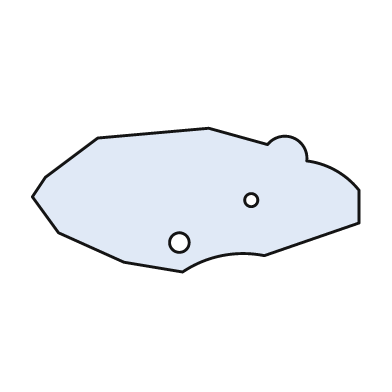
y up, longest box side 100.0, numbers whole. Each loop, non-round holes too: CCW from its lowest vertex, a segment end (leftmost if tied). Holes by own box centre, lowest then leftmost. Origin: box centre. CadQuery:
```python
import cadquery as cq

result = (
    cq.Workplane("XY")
    .moveTo(-4.0, -22.0)
    .threePointArc((8.0, -17.0), (21.0, -17.0))
    .lineTo(50.0, -7.0)
    .lineTo(50.0, 3.0)
    .threePointArc((43.0, 9.0), (34.0, 12.0))
    .threePointArc((30.0, 19.0), (22.0, 17.0))
    .lineTo(4.0, 22.0)
    .lineTo(-30.0, 19.0)
    .lineTo(-46.0, 7.0)
    .lineTo(-50.0, 1.0)
    .lineTo(-42.0, -10.0)
    .lineTo(-22.0, -19.0)
    .close()
    .moveTo(-5.0, -13.0)
    .circle(3.0)
    .moveTo(17.0, 0.0)
    .circle(2.0)
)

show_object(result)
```